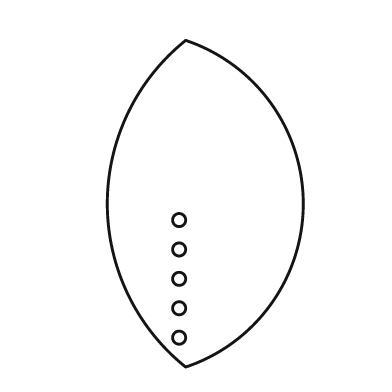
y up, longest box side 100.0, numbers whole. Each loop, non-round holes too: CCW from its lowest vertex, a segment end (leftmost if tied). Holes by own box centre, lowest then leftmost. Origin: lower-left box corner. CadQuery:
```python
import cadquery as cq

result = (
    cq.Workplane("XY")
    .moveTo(24.0, 0.0)
    .threePointArc((60.0, 50.0), (24.0, 100.0))
    .threePointArc((0.0, 50.0), (24.0, 0.0))
    .close()
    .moveTo(22.0, 9.0)
    .circle(2.0)
    .moveTo(22.0, 18.0)
    .circle(2.0)
    .moveTo(22.0, 27.0)
    .circle(2.0)
    .moveTo(22.0, 36.0)
    .circle(2.0)
    .moveTo(22.0, 45.0)
    .circle(2.0)
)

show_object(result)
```